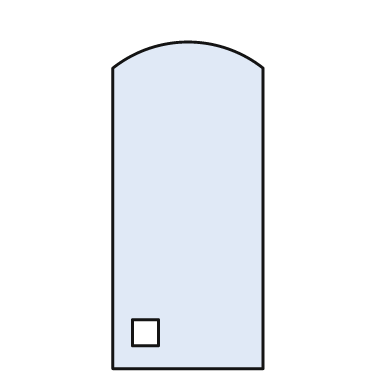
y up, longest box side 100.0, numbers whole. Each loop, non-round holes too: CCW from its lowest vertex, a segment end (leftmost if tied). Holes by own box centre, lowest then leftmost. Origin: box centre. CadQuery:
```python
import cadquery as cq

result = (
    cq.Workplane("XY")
    .moveTo(-23.0, -50.0)
    .lineTo(23.0, -50.0)
    .lineTo(23.0, 42.0)
    .threePointArc((0.0, 50.0), (-23.0, 42.0))
    .close()
    .moveTo(-17.0, -43.0)
    .lineTo(-9.0, -43.0)
    .lineTo(-9.0, -35.0)
    .lineTo(-17.0, -35.0)
    .close()
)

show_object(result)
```